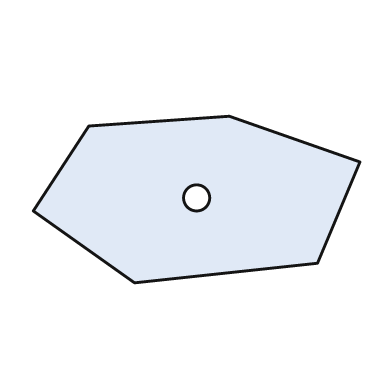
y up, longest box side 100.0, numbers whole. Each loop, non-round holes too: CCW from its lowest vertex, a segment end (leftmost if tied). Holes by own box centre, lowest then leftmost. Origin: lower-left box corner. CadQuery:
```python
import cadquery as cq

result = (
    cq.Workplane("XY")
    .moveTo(31.0, 0.0)
    .lineTo(87.0, 6.0)
    .lineTo(100.0, 37.0)
    .lineTo(60.0, 51.0)
    .lineTo(17.0, 48.0)
    .lineTo(0.0, 22.0)
    .close()
    .moveTo(50.0, 26.0)
    .circle(4.0)
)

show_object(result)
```